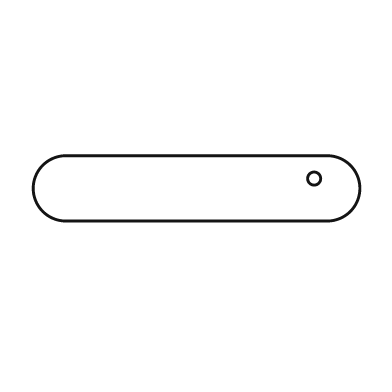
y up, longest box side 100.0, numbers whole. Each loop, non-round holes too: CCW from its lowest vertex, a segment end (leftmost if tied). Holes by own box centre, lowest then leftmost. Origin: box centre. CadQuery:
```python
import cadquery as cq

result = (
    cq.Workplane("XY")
    .moveTo(-40.0, -10.0)
    .lineTo(40.0, -10.0)
    .threePointArc((50.0, 0.0), (40.0, 10.0))
    .lineTo(-40.0, 10.0)
    .threePointArc((-50.0, 0.0), (-40.0, -10.0))
    .close()
    .moveTo(36.0, 3.0)
    .circle(2.0)
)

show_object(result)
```